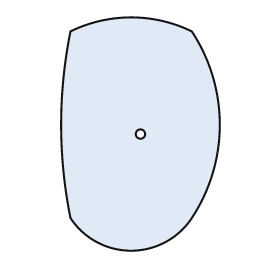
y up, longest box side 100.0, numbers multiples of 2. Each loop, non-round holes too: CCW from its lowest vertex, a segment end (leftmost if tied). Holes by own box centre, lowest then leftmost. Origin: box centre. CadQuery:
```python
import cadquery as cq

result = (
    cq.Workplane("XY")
    .moveTo(-30.0, -36.0)
    .threePointArc((-4.0, -50.0), (22.0, -36.0))
    .threePointArc((34.0, 4.0), (22.0, 44.0))
    .threePointArc((-4.0, 50.0), (-30.0, 44.0))
    .threePointArc((-34.0, 4.0), (-30.0, -36.0))
    .close()
    .moveTo(0.0, 0.0)
    .circle(2.0)
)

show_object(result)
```